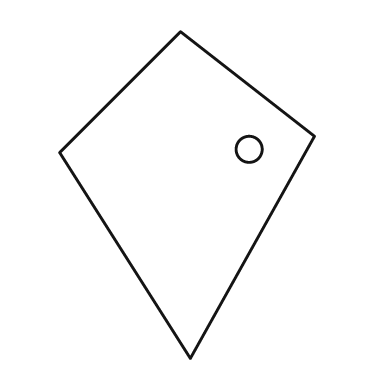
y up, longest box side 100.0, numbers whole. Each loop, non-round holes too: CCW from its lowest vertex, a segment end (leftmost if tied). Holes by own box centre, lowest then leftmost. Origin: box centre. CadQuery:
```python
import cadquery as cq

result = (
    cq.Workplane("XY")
    .moveTo(1.0, -50.0)
    .lineTo(39.0, 18.0)
    .lineTo(-2.0, 50.0)
    .lineTo(-39.0, 13.0)
    .close()
    .moveTo(19.0, 14.0)
    .circle(4.0)
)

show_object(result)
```